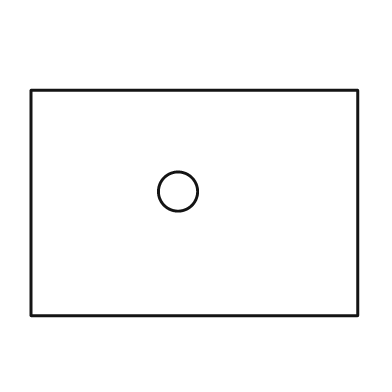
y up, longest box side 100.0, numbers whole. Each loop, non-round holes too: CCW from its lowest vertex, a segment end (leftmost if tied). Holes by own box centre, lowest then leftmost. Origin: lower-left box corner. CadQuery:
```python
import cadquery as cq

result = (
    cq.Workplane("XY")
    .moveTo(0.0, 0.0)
    .lineTo(100.0, 0.0)
    .lineTo(100.0, 69.0)
    .lineTo(0.0, 69.0)
    .close()
    .moveTo(45.0, 38.0)
    .circle(6.0)
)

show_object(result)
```